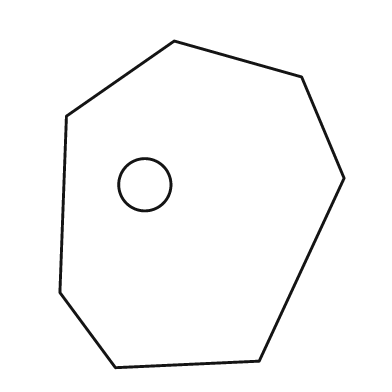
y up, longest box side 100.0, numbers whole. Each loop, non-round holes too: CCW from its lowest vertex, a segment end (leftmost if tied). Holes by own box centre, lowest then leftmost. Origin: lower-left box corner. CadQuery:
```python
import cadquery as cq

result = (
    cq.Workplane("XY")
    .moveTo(17.0, 0.0)
    .lineTo(61.0, 2.0)
    .lineTo(87.0, 58.0)
    .lineTo(74.0, 89.0)
    .lineTo(35.0, 100.0)
    .lineTo(2.0, 77.0)
    .lineTo(0.0, 23.0)
    .close()
    .moveTo(26.0, 56.0)
    .circle(8.0)
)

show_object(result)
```